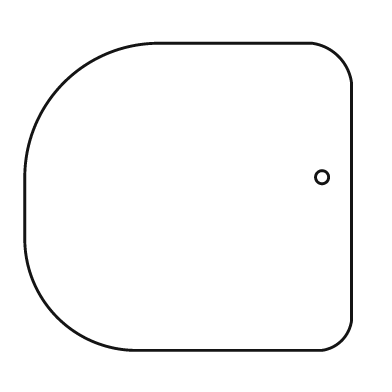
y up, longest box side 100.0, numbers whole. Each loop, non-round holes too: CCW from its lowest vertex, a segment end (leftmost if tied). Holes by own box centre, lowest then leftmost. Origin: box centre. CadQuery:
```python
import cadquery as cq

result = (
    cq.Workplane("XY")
    .moveTo(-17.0, -47.0)
    .lineTo(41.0, -47.0)
    .threePointArc((47.0, -44.0), (50.0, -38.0))
    .lineTo(50.0, 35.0)
    .threePointArc((46.0, 43.0), (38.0, 47.0))
    .lineTo(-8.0, 47.0)
    .threePointArc((-38.0, 35.0), (-50.0, 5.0))
    .lineTo(-50.0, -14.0)
    .threePointArc((-40.0, -37.0), (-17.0, -47.0))
    .close()
    .moveTo(41.0, 6.0)
    .circle(2.0)
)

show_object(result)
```